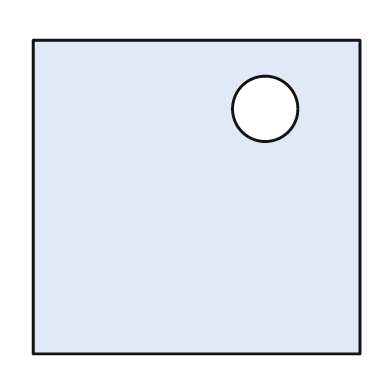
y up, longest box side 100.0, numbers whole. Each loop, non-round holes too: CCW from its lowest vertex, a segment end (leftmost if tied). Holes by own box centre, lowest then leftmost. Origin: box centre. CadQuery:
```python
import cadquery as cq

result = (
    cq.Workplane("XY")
    .moveTo(-50.0, -48.0)
    .lineTo(50.0, -48.0)
    .lineTo(50.0, 48.0)
    .lineTo(-50.0, 48.0)
    .close()
    .moveTo(21.0, 27.0)
    .circle(10.0)
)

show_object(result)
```